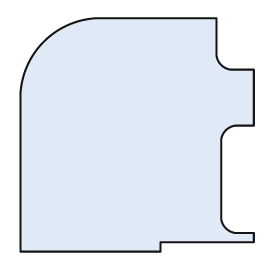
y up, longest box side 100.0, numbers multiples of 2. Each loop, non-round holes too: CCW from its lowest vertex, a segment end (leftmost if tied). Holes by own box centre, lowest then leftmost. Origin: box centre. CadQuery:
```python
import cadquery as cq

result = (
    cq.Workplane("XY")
    .moveTo(-50.0, -50.0)
    .lineTo(10.0, -50.0)
    .lineTo(10.0, -46.0)
    .lineTo(50.0, -46.0)
    .lineTo(50.0, -42.0)
    .lineTo(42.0, -42.0)
    .threePointArc((38.0, -40.0), (36.0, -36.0))
    .lineTo(36.0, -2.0)
    .threePointArc((38.0, 2.0), (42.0, 4.0))
    .lineTo(50.0, 4.0)
    .lineTo(50.0, 28.0)
    .lineTo(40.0, 28.0)
    .threePointArc((36.0, 30.0), (34.0, 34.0))
    .lineTo(34.0, 50.0)
    .lineTo(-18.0, 50.0)
    .threePointArc((-40.0, 40.0), (-50.0, 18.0))
    .close()
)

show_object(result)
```